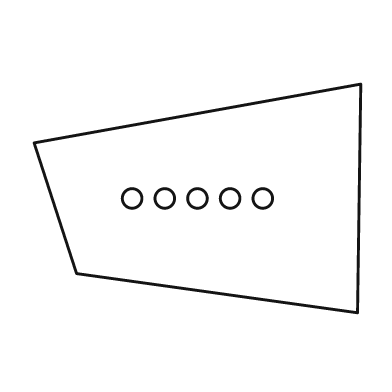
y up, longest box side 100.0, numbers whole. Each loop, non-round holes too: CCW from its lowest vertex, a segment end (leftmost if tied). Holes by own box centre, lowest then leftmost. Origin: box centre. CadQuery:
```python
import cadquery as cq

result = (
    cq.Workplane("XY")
    .moveTo(49.0, -35.0)
    .lineTo(50.0, 35.0)
    .lineTo(-50.0, 17.0)
    .lineTo(-37.0, -23.0)
    .close()
    .moveTo(-20.0, 0.0)
    .circle(3.0)
    .moveTo(-10.0, 0.0)
    .circle(3.0)
    .moveTo(0.0, 0.0)
    .circle(3.0)
    .moveTo(10.0, 0.0)
    .circle(3.0)
    .moveTo(20.0, 0.0)
    .circle(3.0)
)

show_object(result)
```